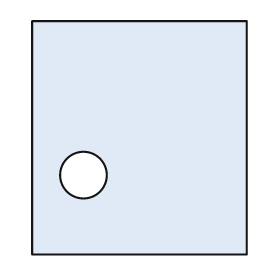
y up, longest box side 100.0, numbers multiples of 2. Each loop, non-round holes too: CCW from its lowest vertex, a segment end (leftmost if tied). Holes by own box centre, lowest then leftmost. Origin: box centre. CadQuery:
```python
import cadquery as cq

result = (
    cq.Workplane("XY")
    .moveTo(-46.0, -50.0)
    .lineTo(46.0, -50.0)
    .lineTo(46.0, 50.0)
    .lineTo(-46.0, 50.0)
    .close()
    .moveTo(-24.0, -16.0)
    .circle(10.0)
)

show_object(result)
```